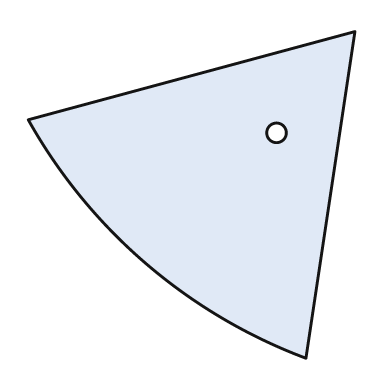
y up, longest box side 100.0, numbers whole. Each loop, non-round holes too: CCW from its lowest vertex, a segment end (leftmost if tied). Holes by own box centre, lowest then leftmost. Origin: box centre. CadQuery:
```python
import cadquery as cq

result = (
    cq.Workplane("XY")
    .moveTo(35.0, -50.0)
    .lineTo(50.0, 50.0)
    .lineTo(-50.0, 23.0)
    .threePointArc((-14.0, -21.0), (35.0, -50.0))
    .close()
    .moveTo(26.0, 19.0)
    .circle(3.0)
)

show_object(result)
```